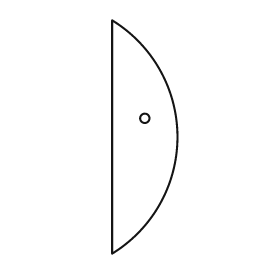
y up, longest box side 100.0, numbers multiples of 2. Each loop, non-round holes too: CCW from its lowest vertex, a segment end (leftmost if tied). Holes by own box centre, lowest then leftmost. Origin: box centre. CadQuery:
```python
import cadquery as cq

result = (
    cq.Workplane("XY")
    .moveTo(-14.0, -50.0)
    .threePointArc((14.0, 0.0), (-14.0, 50.0))
    .close()
    .moveTo(0.0, 8.0)
    .circle(2.0)
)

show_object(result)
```